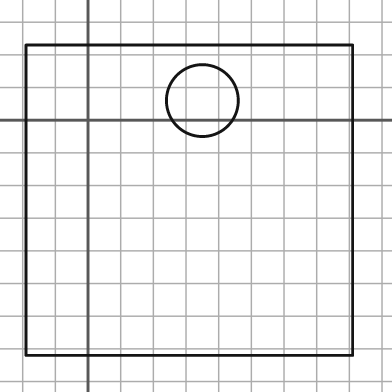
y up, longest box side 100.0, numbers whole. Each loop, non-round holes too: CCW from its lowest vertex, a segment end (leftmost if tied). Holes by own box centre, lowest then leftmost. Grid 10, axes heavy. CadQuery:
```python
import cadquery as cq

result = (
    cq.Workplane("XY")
    .moveTo(-19.0, -72.0)
    .lineTo(81.0, -72.0)
    .lineTo(81.0, 23.0)
    .lineTo(-19.0, 23.0)
    .close()
    .moveTo(35.0, 6.0)
    .circle(11.0)
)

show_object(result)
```